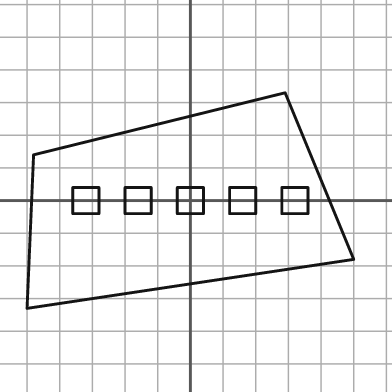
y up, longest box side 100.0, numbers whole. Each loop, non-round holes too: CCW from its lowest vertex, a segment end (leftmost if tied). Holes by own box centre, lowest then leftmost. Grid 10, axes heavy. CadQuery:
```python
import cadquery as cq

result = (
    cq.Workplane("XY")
    .moveTo(-50.0, -33.0)
    .lineTo(50.0, -18.0)
    .lineTo(29.0, 33.0)
    .lineTo(-48.0, 14.0)
    .close()
    .moveTo(-36.0, -4.0)
    .lineTo(-28.0, -4.0)
    .lineTo(-28.0, 4.0)
    .lineTo(-36.0, 4.0)
    .close()
    .moveTo(-20.0, -4.0)
    .lineTo(-12.0, -4.0)
    .lineTo(-12.0, 4.0)
    .lineTo(-20.0, 4.0)
    .close()
    .moveTo(-4.0, -4.0)
    .lineTo(4.0, -4.0)
    .lineTo(4.0, 4.0)
    .lineTo(-4.0, 4.0)
    .close()
    .moveTo(12.0, -4.0)
    .lineTo(20.0, -4.0)
    .lineTo(20.0, 4.0)
    .lineTo(12.0, 4.0)
    .close()
    .moveTo(28.0, -4.0)
    .lineTo(36.0, -4.0)
    .lineTo(36.0, 4.0)
    .lineTo(28.0, 4.0)
    .close()
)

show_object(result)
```